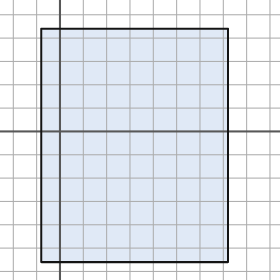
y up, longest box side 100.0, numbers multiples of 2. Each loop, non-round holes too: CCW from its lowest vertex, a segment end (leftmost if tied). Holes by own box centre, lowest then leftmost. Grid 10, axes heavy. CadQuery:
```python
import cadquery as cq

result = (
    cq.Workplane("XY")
    .moveTo(-8.0, -56.0)
    .lineTo(72.0, -56.0)
    .lineTo(72.0, 44.0)
    .lineTo(-8.0, 44.0)
    .close()
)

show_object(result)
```